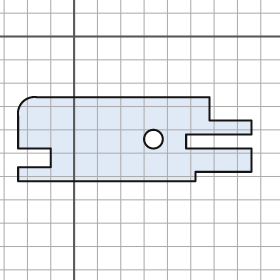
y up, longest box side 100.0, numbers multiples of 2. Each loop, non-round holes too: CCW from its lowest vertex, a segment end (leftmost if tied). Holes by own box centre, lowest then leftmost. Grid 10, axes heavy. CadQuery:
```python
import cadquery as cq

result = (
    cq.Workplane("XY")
    .moveTo(-24.0, -62.0)
    .lineTo(52.0, -62.0)
    .lineTo(52.0, -58.0)
    .lineTo(76.0, -58.0)
    .lineTo(76.0, -48.0)
    .lineTo(48.0, -48.0)
    .lineTo(48.0, -42.0)
    .lineTo(76.0, -42.0)
    .lineTo(76.0, -36.0)
    .lineTo(58.0, -36.0)
    .lineTo(58.0, -26.0)
    .lineTo(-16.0, -26.0)
    .threePointArc((-22.0, -28.0), (-24.0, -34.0))
    .lineTo(-24.0, -48.0)
    .lineTo(-10.0, -48.0)
    .lineTo(-10.0, -56.0)
    .lineTo(-24.0, -56.0)
    .close()
    .moveTo(34.0, -44.0)
    .circle(4.0)
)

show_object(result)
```